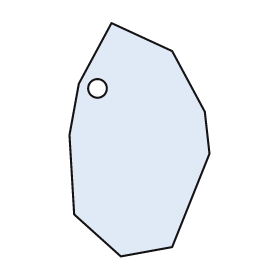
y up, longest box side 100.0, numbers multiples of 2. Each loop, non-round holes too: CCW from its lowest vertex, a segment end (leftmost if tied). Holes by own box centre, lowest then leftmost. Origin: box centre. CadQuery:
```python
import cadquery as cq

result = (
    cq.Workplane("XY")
    .moveTo(-8.0, -50.0)
    .lineTo(14.0, -46.0)
    .lineTo(30.0, -6.0)
    .lineTo(28.0, 12.0)
    .lineTo(14.0, 38.0)
    .lineTo(-12.0, 50.0)
    .lineTo(-26.0, 24.0)
    .lineTo(-30.0, 2.0)
    .lineTo(-28.0, -32.0)
    .close()
    .moveTo(-18.0, 22.0)
    .circle(4.0)
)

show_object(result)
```